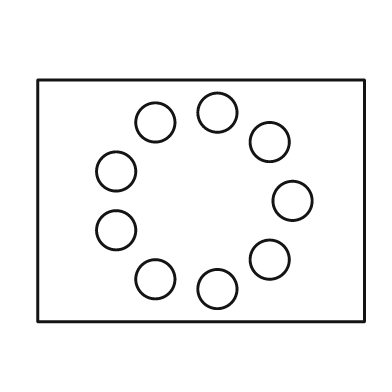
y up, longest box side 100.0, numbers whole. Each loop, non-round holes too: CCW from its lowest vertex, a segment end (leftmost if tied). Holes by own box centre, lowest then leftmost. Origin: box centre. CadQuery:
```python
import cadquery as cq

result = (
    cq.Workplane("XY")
    .moveTo(-50.0, -37.0)
    .lineTo(50.0, -37.0)
    .lineTo(50.0, 37.0)
    .lineTo(-50.0, 37.0)
    .close()
    .moveTo(5.0, -27.0)
    .circle(6.0)
    .moveTo(-14.0, -24.0)
    .circle(6.0)
    .moveTo(21.0, -18.0)
    .circle(6.0)
    .moveTo(-26.0, -9.0)
    .circle(6.0)
    .moveTo(28.0, 0.0)
    .circle(6.0)
    .moveTo(-26.0, 9.0)
    .circle(6.0)
    .moveTo(21.0, 18.0)
    .circle(6.0)
    .moveTo(-14.0, 24.0)
    .circle(6.0)
    .moveTo(5.0, 27.0)
    .circle(6.0)
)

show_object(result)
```